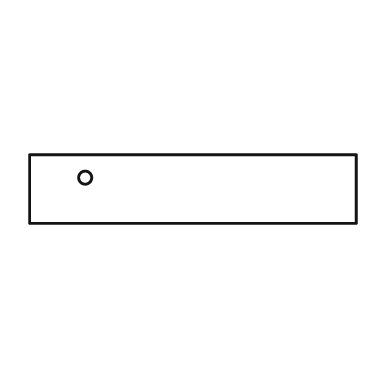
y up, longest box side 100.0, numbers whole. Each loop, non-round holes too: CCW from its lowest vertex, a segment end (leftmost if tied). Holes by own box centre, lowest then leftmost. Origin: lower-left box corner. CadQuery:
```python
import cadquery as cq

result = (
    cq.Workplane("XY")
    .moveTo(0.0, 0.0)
    .lineTo(100.0, 0.0)
    .lineTo(100.0, 21.0)
    .lineTo(0.0, 21.0)
    .close()
    .moveTo(17.0, 14.0)
    .circle(2.0)
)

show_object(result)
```